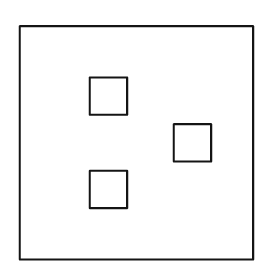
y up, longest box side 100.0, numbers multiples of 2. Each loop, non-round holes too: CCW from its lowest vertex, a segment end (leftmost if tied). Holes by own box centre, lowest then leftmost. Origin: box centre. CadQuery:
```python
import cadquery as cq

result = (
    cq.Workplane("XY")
    .moveTo(-50.0, -50.0)
    .lineTo(50.0, -50.0)
    .lineTo(50.0, 50.0)
    .lineTo(-50.0, 50.0)
    .close()
    .moveTo(-20.0, -28.0)
    .lineTo(-4.0, -28.0)
    .lineTo(-4.0, -12.0)
    .lineTo(-20.0, -12.0)
    .close()
    .moveTo(16.0, -8.0)
    .lineTo(32.0, -8.0)
    .lineTo(32.0, 8.0)
    .lineTo(16.0, 8.0)
    .close()
    .moveTo(-20.0, 12.0)
    .lineTo(-4.0, 12.0)
    .lineTo(-4.0, 28.0)
    .lineTo(-20.0, 28.0)
    .close()
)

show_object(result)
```